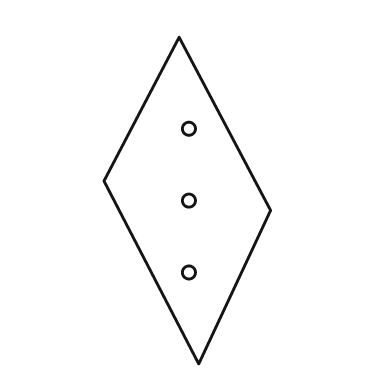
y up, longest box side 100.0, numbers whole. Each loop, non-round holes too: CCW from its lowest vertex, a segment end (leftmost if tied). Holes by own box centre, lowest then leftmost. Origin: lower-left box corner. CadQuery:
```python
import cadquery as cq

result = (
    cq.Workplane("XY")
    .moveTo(29.0, 0.0)
    .lineTo(51.0, 47.0)
    .lineTo(23.0, 100.0)
    .lineTo(0.0, 56.0)
    .close()
    .moveTo(26.0, 28.0)
    .circle(2.0)
    .moveTo(26.0, 50.0)
    .circle(2.0)
    .moveTo(26.0, 72.0)
    .circle(2.0)
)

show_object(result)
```